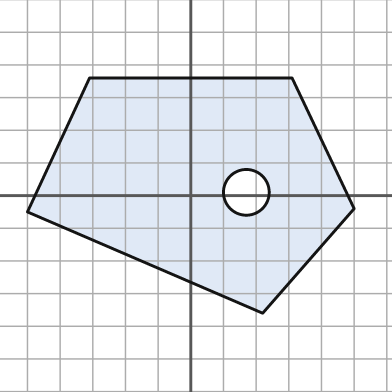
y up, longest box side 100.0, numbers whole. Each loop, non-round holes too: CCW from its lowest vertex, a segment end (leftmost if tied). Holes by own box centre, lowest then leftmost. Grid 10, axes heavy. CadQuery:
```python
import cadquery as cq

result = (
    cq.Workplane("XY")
    .moveTo(22.0, -36.0)
    .lineTo(50.0, -4.0)
    .lineTo(31.0, 36.0)
    .lineTo(-31.0, 36.0)
    .lineTo(-50.0, -5.0)
    .close()
    .moveTo(17.0, 1.0)
    .circle(7.0)
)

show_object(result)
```